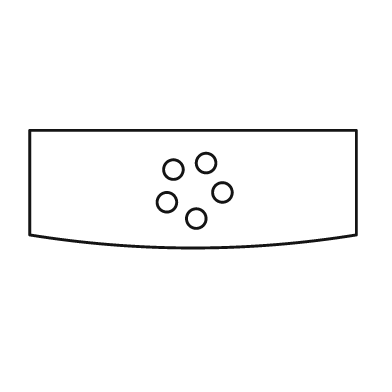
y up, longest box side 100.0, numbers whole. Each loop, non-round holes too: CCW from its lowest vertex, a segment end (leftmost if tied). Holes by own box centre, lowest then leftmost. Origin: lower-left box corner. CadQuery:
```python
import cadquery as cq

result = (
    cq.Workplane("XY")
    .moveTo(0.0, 4.0)
    .threePointArc((50.0, 0.0), (100.0, 4.0))
    .lineTo(100.0, 36.0)
    .lineTo(0.0, 36.0)
    .close()
    .moveTo(51.0, 9.0)
    .circle(3.0)
    .moveTo(42.0, 14.0)
    .circle(3.0)
    .moveTo(59.0, 17.0)
    .circle(3.0)
    .moveTo(44.0, 24.0)
    .circle(3.0)
    .moveTo(54.0, 26.0)
    .circle(3.0)
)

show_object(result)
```